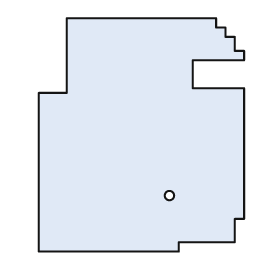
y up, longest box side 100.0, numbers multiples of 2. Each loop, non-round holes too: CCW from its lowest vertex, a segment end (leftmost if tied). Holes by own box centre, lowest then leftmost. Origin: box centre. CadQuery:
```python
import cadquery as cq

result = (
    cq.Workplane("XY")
    .moveTo(-44.0, -50.0)
    .lineTo(16.0, -50.0)
    .lineTo(16.0, -46.0)
    .lineTo(40.0, -46.0)
    .lineTo(40.0, -36.0)
    .lineTo(44.0, -36.0)
    .lineTo(44.0, 20.0)
    .lineTo(22.0, 20.0)
    .lineTo(22.0, 32.0)
    .lineTo(44.0, 32.0)
    .lineTo(44.0, 36.0)
    .lineTo(40.0, 36.0)
    .lineTo(40.0, 42.0)
    .lineTo(36.0, 42.0)
    .lineTo(36.0, 46.0)
    .lineTo(32.0, 46.0)
    .lineTo(32.0, 50.0)
    .lineTo(-32.0, 50.0)
    .lineTo(-32.0, 18.0)
    .lineTo(-44.0, 18.0)
    .close()
    .moveTo(12.0, -26.0)
    .circle(2.0)
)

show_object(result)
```